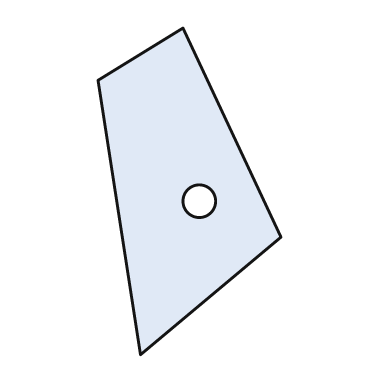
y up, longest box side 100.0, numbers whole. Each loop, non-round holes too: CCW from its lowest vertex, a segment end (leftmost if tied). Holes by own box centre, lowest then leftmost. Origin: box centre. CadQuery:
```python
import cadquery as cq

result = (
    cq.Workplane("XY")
    .moveTo(-15.0, -50.0)
    .lineTo(28.0, -14.0)
    .lineTo(-2.0, 50.0)
    .lineTo(-28.0, 34.0)
    .close()
    .moveTo(3.0, -3.0)
    .circle(5.0)
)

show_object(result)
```